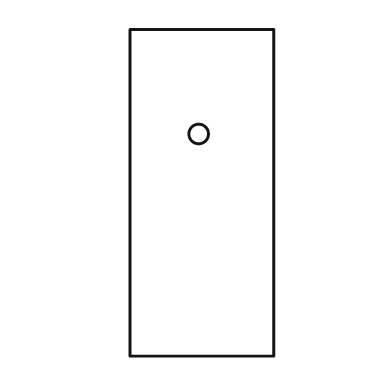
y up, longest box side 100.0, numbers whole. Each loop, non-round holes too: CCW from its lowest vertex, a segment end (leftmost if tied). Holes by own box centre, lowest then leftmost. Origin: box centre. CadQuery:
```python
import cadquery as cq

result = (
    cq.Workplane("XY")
    .moveTo(-22.0, -50.0)
    .lineTo(22.0, -50.0)
    .lineTo(22.0, 50.0)
    .lineTo(-22.0, 50.0)
    .close()
    .moveTo(-1.0, 18.0)
    .circle(3.0)
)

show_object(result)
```